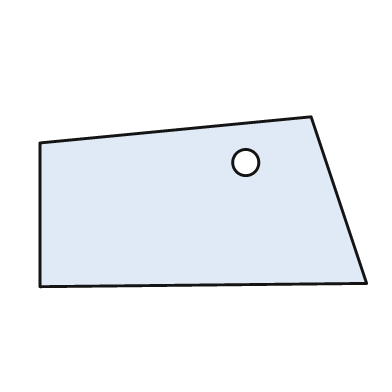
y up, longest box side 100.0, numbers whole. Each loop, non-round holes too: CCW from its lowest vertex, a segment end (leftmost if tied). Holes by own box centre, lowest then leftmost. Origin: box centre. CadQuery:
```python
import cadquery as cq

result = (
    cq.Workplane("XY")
    .moveTo(-50.0, -26.0)
    .lineTo(50.0, -25.0)
    .lineTo(33.0, 26.0)
    .lineTo(-50.0, 18.0)
    .close()
    .moveTo(13.0, 12.0)
    .circle(4.0)
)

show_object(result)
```